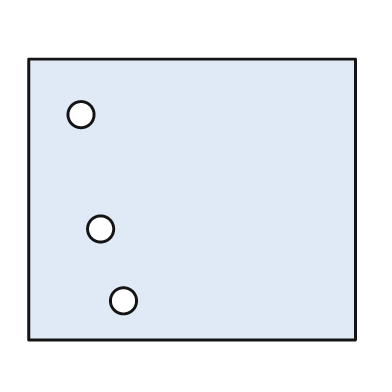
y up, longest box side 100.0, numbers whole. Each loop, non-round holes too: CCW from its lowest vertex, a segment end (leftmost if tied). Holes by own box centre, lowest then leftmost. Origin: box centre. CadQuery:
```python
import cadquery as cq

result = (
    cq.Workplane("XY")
    .moveTo(-50.0, -43.0)
    .lineTo(50.0, -43.0)
    .lineTo(50.0, 43.0)
    .lineTo(-50.0, 43.0)
    .close()
    .moveTo(-21.0, -31.0)
    .circle(4.0)
    .moveTo(-28.0, -9.0)
    .circle(4.0)
    .moveTo(-34.0, 26.0)
    .circle(4.0)
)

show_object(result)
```